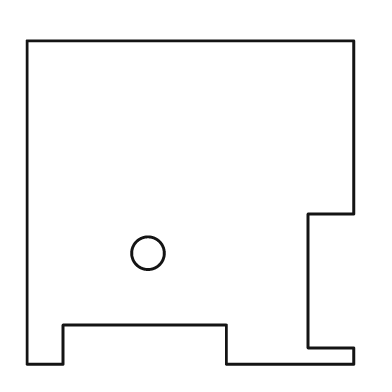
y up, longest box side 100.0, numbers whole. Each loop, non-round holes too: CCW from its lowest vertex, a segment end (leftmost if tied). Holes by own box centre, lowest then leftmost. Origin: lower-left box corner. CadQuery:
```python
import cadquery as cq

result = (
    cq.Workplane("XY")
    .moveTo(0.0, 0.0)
    .lineTo(11.0, 0.0)
    .lineTo(11.0, 12.0)
    .lineTo(61.0, 12.0)
    .lineTo(61.0, 0.0)
    .lineTo(100.0, 0.0)
    .lineTo(100.0, 5.0)
    .lineTo(86.0, 5.0)
    .lineTo(86.0, 46.0)
    .lineTo(100.0, 46.0)
    .lineTo(100.0, 99.0)
    .lineTo(0.0, 99.0)
    .close()
    .moveTo(37.0, 34.0)
    .circle(5.0)
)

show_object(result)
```